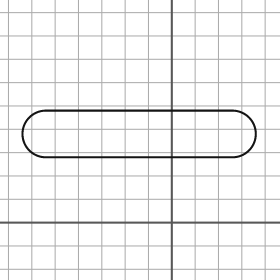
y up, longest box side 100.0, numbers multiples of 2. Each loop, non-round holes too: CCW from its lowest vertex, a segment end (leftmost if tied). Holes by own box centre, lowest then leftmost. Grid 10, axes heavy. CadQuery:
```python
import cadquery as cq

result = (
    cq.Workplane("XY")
    .moveTo(-54.0, 28.0)
    .lineTo(26.0, 28.0)
    .threePointArc((36.0, 38.0), (26.0, 48.0))
    .lineTo(-54.0, 48.0)
    .threePointArc((-64.0, 38.0), (-54.0, 28.0))
    .close()
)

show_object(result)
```